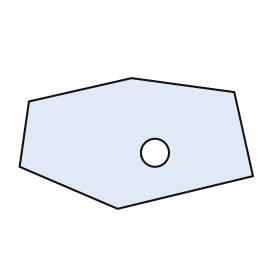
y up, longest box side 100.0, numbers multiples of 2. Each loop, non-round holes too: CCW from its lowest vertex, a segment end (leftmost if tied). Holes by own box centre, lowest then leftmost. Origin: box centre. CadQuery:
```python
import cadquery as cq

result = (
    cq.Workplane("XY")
    .moveTo(-8.0, -28.0)
    .lineTo(50.0, -14.0)
    .lineTo(42.0, 22.0)
    .lineTo(-2.0, 28.0)
    .lineTo(-46.0, 18.0)
    .lineTo(-50.0, -10.0)
    .close()
    .moveTo(8.0, -4.0)
    .circle(6.0)
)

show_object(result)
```